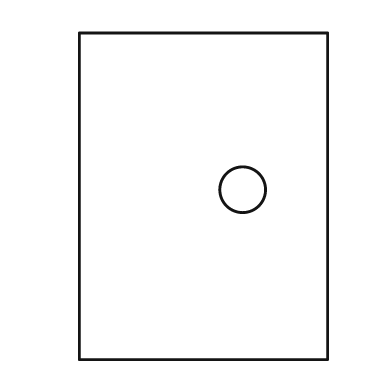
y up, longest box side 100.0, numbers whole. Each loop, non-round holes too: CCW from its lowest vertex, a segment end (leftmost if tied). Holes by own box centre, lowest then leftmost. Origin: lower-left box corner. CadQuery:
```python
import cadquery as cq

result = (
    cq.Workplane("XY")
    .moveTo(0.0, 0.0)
    .lineTo(76.0, 0.0)
    .lineTo(76.0, 100.0)
    .lineTo(0.0, 100.0)
    .close()
    .moveTo(50.0, 52.0)
    .circle(7.0)
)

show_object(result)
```